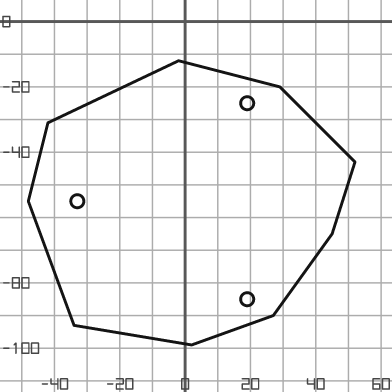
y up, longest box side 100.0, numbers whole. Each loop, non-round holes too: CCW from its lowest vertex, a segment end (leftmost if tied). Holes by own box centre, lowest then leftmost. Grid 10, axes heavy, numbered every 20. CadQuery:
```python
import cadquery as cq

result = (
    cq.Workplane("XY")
    .moveTo(2.0, -99.0)
    .lineTo(27.0, -90.0)
    .lineTo(45.0, -65.0)
    .lineTo(52.0, -43.0)
    .lineTo(29.0, -20.0)
    .lineTo(-2.0, -12.0)
    .lineTo(-42.0, -31.0)
    .lineTo(-48.0, -55.0)
    .lineTo(-34.0, -93.0)
    .close()
    .moveTo(19.0, -85.0)
    .circle(2.0)
    .moveTo(-33.0, -55.0)
    .circle(2.0)
    .moveTo(19.0, -25.0)
    .circle(2.0)
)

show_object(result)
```